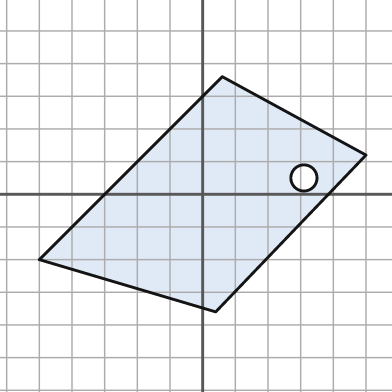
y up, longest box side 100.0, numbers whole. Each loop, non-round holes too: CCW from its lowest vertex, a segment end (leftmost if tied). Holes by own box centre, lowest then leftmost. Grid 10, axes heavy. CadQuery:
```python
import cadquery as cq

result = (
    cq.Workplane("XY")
    .moveTo(4.0, -36.0)
    .lineTo(50.0, 12.0)
    .lineTo(6.0, 36.0)
    .lineTo(-50.0, -20.0)
    .close()
    .moveTo(31.0, 5.0)
    .circle(4.0)
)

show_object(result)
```